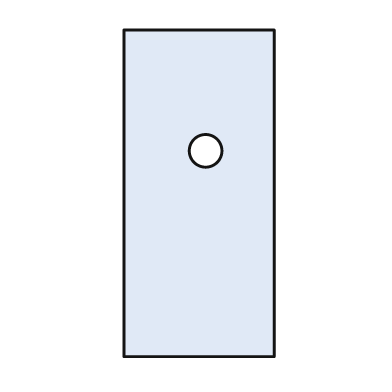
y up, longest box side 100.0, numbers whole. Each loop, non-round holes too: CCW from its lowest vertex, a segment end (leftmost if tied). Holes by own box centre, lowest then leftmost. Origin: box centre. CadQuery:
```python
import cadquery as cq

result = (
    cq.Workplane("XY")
    .moveTo(-23.0, -50.0)
    .lineTo(23.0, -50.0)
    .lineTo(23.0, 50.0)
    .lineTo(-23.0, 50.0)
    .close()
    .moveTo(2.0, 13.0)
    .circle(5.0)
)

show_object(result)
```